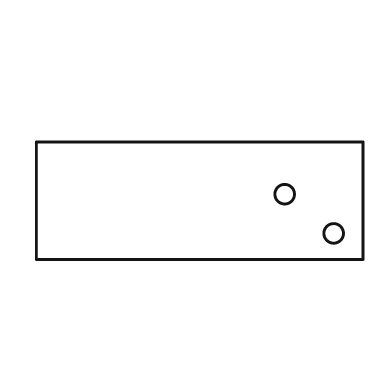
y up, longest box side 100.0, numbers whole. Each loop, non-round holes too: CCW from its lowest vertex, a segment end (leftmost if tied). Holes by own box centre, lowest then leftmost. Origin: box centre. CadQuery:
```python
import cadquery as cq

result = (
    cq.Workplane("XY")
    .moveTo(-50.0, -18.0)
    .lineTo(50.0, -18.0)
    .lineTo(50.0, 18.0)
    .lineTo(-50.0, 18.0)
    .close()
    .moveTo(41.0, -10.0)
    .circle(3.0)
    .moveTo(26.0, 2.0)
    .circle(3.0)
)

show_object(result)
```